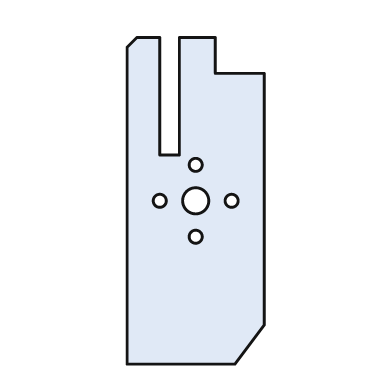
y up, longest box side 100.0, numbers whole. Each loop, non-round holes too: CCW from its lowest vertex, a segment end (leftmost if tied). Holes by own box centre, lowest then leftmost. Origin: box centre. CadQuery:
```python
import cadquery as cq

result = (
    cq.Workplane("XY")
    .moveTo(-21.0, -50.0)
    .lineTo(12.0, -50.0)
    .lineTo(21.0, -38.0)
    .lineTo(21.0, 39.0)
    .lineTo(6.0, 39.0)
    .lineTo(6.0, 50.0)
    .lineTo(-5.0, 50.0)
    .lineTo(-5.0, 14.0)
    .lineTo(-11.0, 14.0)
    .lineTo(-11.0, 50.0)
    .lineTo(-18.0, 50.0)
    .lineTo(-21.0, 47.0)
    .close()
    .moveTo(0.0, -11.0)
    .circle(2.0)
    .moveTo(-11.0, 0.0)
    .circle(2.0)
    .moveTo(0.0, 0.0)
    .circle(4.0)
    .moveTo(11.0, 0.0)
    .circle(2.0)
    .moveTo(0.0, 11.0)
    .circle(2.0)
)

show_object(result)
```